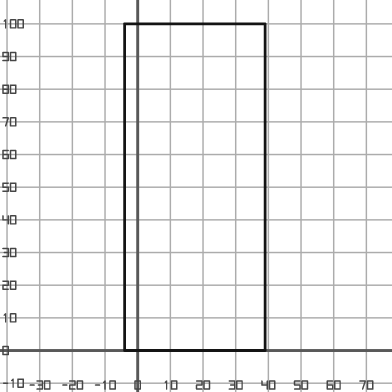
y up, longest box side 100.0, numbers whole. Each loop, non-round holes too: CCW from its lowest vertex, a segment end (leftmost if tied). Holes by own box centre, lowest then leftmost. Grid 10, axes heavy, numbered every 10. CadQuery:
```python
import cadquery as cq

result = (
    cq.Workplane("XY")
    .moveTo(-4.0, 0.0)
    .lineTo(39.0, 0.0)
    .lineTo(39.0, 100.0)
    .lineTo(-4.0, 100.0)
    .close()
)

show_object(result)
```